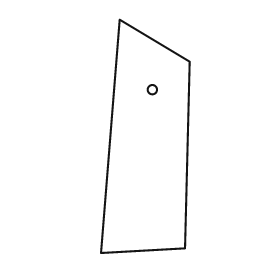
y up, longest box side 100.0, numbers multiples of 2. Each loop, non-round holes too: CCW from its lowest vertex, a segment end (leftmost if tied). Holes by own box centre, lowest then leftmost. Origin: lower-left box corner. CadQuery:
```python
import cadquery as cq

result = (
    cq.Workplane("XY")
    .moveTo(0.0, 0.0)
    .lineTo(36.0, 2.0)
    .lineTo(38.0, 82.0)
    .lineTo(8.0, 100.0)
    .close()
    .moveTo(22.0, 70.0)
    .circle(2.0)
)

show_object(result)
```